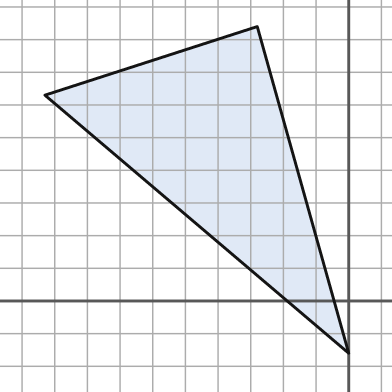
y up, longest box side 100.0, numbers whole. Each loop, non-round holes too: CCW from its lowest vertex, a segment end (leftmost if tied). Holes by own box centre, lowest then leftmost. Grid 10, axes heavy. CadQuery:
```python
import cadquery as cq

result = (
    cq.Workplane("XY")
    .moveTo(0.0, -16.0)
    .lineTo(-28.0, 84.0)
    .lineTo(-93.0, 63.0)
    .close()
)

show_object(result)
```